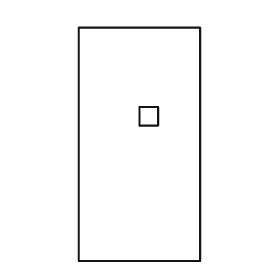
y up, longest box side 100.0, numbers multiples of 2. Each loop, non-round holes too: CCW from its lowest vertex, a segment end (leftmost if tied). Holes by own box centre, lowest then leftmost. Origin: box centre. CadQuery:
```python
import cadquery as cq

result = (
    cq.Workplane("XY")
    .moveTo(-26.0, -50.0)
    .lineTo(26.0, -50.0)
    .lineTo(26.0, 50.0)
    .lineTo(-26.0, 50.0)
    .close()
    .moveTo(0.0, 8.0)
    .lineTo(8.0, 8.0)
    .lineTo(8.0, 16.0)
    .lineTo(0.0, 16.0)
    .close()
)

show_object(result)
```